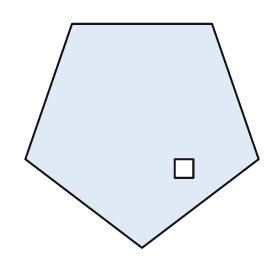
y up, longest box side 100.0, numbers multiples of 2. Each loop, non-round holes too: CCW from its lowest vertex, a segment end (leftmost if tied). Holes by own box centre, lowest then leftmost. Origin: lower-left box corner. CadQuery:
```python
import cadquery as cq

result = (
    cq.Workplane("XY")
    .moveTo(50.0, 0.0)
    .lineTo(100.0, 38.0)
    .lineTo(80.0, 96.0)
    .lineTo(20.0, 96.0)
    .lineTo(0.0, 38.0)
    .close()
    .moveTo(64.0, 30.0)
    .lineTo(72.0, 30.0)
    .lineTo(72.0, 38.0)
    .lineTo(64.0, 38.0)
    .close()
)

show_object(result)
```